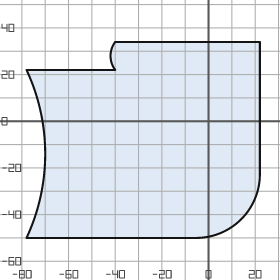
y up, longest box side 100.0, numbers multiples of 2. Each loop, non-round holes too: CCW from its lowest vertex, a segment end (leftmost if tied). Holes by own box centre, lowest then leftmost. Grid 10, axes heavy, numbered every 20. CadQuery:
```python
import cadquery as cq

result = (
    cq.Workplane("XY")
    .moveTo(-78.0, -50.0)
    .lineTo(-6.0, -50.0)
    .threePointArc((14.0, -42.0), (22.0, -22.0))
    .lineTo(22.0, 34.0)
    .lineTo(-40.0, 34.0)
    .threePointArc((-42.0, 28.0), (-40.0, 22.0))
    .lineTo(-78.0, 22.0)
    .threePointArc((-70.0, -14.0), (-78.0, -50.0))
    .close()
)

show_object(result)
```